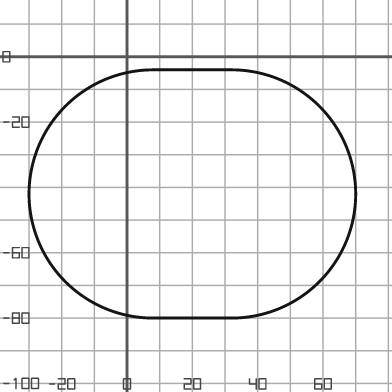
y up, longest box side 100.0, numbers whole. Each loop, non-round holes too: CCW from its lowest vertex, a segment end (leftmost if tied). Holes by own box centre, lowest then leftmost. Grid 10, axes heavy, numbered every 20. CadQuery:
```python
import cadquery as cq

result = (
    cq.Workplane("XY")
    .moveTo(8.0, -80.0)
    .lineTo(32.0, -80.0)
    .threePointArc((70.0, -42.0), (32.0, -4.0))
    .lineTo(8.0, -4.0)
    .threePointArc((-30.0, -42.0), (8.0, -80.0))
    .close()
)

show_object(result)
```